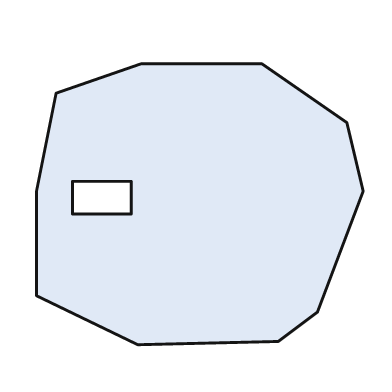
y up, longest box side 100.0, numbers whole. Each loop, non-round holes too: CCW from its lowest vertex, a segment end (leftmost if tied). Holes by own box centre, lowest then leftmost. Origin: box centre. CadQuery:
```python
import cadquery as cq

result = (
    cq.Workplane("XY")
    .moveTo(-19.0, -43.0)
    .lineTo(24.0, -42.0)
    .lineTo(36.0, -33.0)
    .lineTo(50.0, 4.0)
    .lineTo(45.0, 25.0)
    .lineTo(19.0, 43.0)
    .lineTo(-18.0, 43.0)
    .lineTo(-44.0, 34.0)
    .lineTo(-50.0, 4.0)
    .lineTo(-50.0, -28.0)
    .close()
    .moveTo(-39.0, -3.0)
    .lineTo(-21.0, -3.0)
    .lineTo(-21.0, 7.0)
    .lineTo(-39.0, 7.0)
    .close()
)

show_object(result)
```